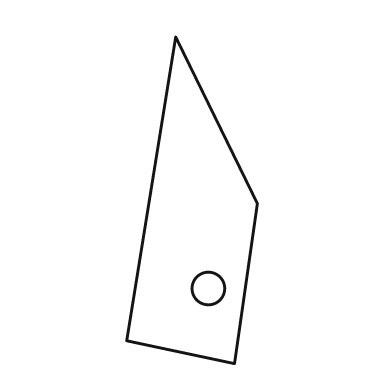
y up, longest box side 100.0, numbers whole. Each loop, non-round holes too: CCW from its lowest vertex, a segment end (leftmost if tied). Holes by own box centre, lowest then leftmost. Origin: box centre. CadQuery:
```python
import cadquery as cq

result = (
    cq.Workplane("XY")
    .moveTo(13.0, -50.0)
    .lineTo(20.0, -1.0)
    .lineTo(-5.0, 50.0)
    .lineTo(-20.0, -43.0)
    .close()
    .moveTo(5.0, -27.0)
    .circle(5.0)
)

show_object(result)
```